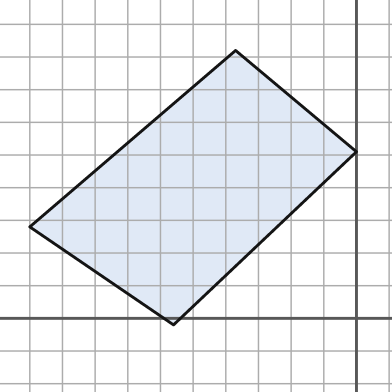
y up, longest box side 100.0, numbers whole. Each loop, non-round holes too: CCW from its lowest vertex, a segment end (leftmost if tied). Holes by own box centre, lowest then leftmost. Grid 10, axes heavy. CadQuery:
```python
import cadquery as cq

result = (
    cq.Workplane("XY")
    .moveTo(-56.0, -2.0)
    .lineTo(0.0, 51.0)
    .lineTo(-37.0, 82.0)
    .lineTo(-100.0, 28.0)
    .close()
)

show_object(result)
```